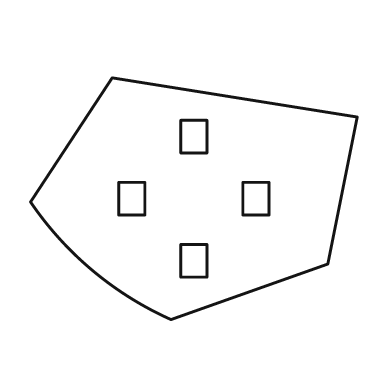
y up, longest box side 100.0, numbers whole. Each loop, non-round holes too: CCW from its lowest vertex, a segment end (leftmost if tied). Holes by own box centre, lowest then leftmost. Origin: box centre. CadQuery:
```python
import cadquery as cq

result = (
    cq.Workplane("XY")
    .moveTo(-7.0, -37.0)
    .lineTo(41.0, -20.0)
    .lineTo(50.0, 25.0)
    .lineTo(-25.0, 37.0)
    .lineTo(-50.0, -1.0)
    .threePointArc((-31.0, -22.0), (-7.0, -37.0))
    .close()
    .moveTo(-4.0, -24.0)
    .lineTo(4.0, -24.0)
    .lineTo(4.0, -14.0)
    .lineTo(-4.0, -14.0)
    .close()
    .moveTo(-23.0, -5.0)
    .lineTo(-15.0, -5.0)
    .lineTo(-15.0, 5.0)
    .lineTo(-23.0, 5.0)
    .close()
    .moveTo(15.0, -5.0)
    .lineTo(23.0, -5.0)
    .lineTo(23.0, 5.0)
    .lineTo(15.0, 5.0)
    .close()
    .moveTo(-4.0, 14.0)
    .lineTo(4.0, 14.0)
    .lineTo(4.0, 24.0)
    .lineTo(-4.0, 24.0)
    .close()
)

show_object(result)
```